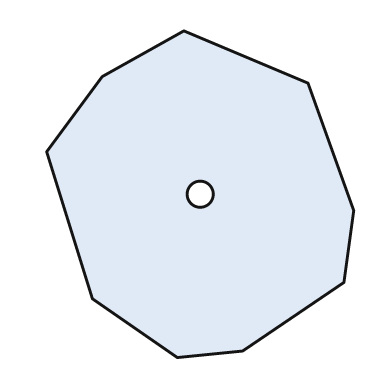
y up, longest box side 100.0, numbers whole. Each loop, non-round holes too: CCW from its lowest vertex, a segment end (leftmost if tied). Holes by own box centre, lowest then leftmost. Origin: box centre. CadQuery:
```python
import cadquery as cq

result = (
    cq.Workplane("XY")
    .moveTo(-7.0, -50.0)
    .lineTo(13.0, -48.0)
    .lineTo(44.0, -27.0)
    .lineTo(47.0, -5.0)
    .lineTo(33.0, 34.0)
    .lineTo(-5.0, 50.0)
    .lineTo(-30.0, 36.0)
    .lineTo(-47.0, 13.0)
    .lineTo(-33.0, -32.0)
    .close()
    .moveTo(0.0, 0.0)
    .circle(4.0)
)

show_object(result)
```